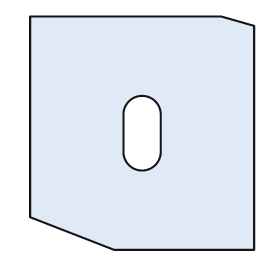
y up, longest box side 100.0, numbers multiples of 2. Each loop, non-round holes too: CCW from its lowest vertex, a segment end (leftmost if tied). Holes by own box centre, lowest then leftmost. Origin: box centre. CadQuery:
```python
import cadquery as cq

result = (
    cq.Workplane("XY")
    .moveTo(-12.0, -50.0)
    .lineTo(48.0, -50.0)
    .lineTo(48.0, 46.0)
    .lineTo(34.0, 50.0)
    .lineTo(-48.0, 50.0)
    .lineTo(-48.0, -36.0)
    .close()
    .moveTo(-8.0, -8.0)
    .threePointArc((0.0, -16.0), (8.0, -8.0))
    .lineTo(8.0, 8.0)
    .threePointArc((0.0, 16.0), (-8.0, 8.0))
    .close()
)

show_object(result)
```